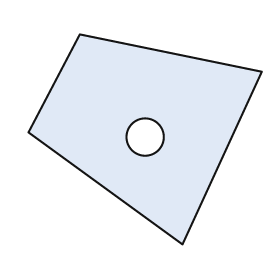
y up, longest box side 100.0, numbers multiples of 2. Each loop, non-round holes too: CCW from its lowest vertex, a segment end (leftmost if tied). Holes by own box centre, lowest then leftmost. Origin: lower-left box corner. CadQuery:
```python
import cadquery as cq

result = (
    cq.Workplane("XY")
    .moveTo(66.0, 0.0)
    .lineTo(100.0, 74.0)
    .lineTo(22.0, 90.0)
    .lineTo(0.0, 48.0)
    .close()
    .moveTo(50.0, 46.0)
    .circle(8.0)
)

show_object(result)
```